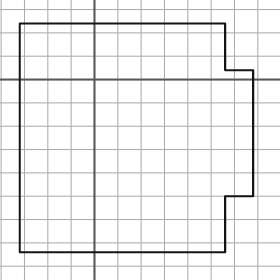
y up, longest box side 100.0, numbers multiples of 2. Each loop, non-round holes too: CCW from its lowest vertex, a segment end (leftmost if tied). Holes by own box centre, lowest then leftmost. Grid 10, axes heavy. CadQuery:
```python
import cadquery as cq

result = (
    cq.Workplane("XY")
    .moveTo(-32.0, -74.0)
    .lineTo(56.0, -74.0)
    .lineTo(56.0, -50.0)
    .lineTo(68.0, -50.0)
    .lineTo(68.0, 4.0)
    .lineTo(56.0, 4.0)
    .lineTo(56.0, 24.0)
    .lineTo(-32.0, 24.0)
    .close()
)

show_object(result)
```